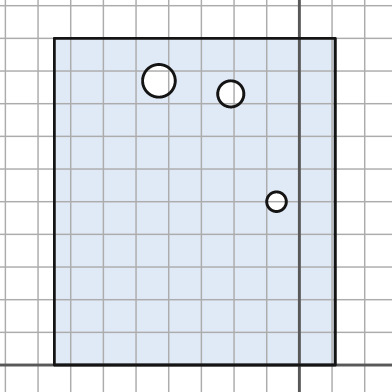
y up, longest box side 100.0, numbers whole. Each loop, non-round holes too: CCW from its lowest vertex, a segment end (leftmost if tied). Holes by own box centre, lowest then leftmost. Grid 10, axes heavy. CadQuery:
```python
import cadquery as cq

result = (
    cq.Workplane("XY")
    .moveTo(-75.0, 0.0)
    .lineTo(11.0, 0.0)
    .lineTo(11.0, 100.0)
    .lineTo(-75.0, 100.0)
    .close()
    .moveTo(-7.0, 50.0)
    .circle(3.0)
    .moveTo(-21.0, 83.0)
    .circle(4.0)
    .moveTo(-43.0, 87.0)
    .circle(5.0)
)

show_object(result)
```